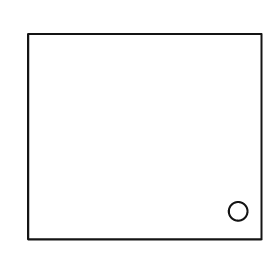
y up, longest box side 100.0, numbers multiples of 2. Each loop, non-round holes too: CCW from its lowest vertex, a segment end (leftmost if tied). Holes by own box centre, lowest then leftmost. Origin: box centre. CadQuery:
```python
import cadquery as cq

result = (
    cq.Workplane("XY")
    .moveTo(-50.0, -44.0)
    .lineTo(50.0, -44.0)
    .lineTo(50.0, 44.0)
    .lineTo(-50.0, 44.0)
    .close()
    .moveTo(40.0, -32.0)
    .circle(4.0)
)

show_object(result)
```